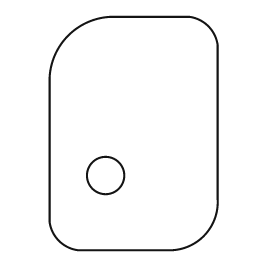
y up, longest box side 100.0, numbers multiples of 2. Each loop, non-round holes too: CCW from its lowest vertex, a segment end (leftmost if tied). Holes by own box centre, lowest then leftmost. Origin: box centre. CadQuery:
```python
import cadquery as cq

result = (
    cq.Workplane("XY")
    .moveTo(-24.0, -50.0)
    .lineTo(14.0, -50.0)
    .threePointArc((30.0, -44.0), (36.0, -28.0))
    .lineTo(36.0, 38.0)
    .threePointArc((32.0, 46.0), (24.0, 50.0))
    .lineTo(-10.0, 50.0)
    .threePointArc((-28.0, 42.0), (-36.0, 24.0))
    .lineTo(-36.0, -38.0)
    .threePointArc((-32.0, -46.0), (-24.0, -50.0))
    .close()
    .moveTo(-12.0, -18.0)
    .circle(8.0)
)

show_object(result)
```